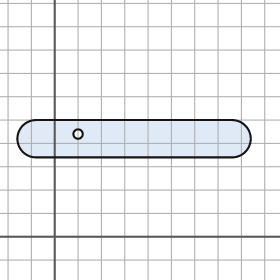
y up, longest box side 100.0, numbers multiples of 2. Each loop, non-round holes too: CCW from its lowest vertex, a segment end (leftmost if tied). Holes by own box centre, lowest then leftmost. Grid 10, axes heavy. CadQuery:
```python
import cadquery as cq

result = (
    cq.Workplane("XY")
    .moveTo(-8.0, 34.0)
    .lineTo(76.0, 34.0)
    .threePointArc((84.0, 42.0), (76.0, 50.0))
    .lineTo(-8.0, 50.0)
    .threePointArc((-16.0, 42.0), (-8.0, 34.0))
    .close()
    .moveTo(10.0, 44.0)
    .circle(2.0)
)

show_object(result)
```